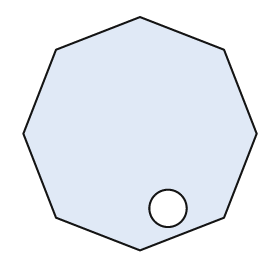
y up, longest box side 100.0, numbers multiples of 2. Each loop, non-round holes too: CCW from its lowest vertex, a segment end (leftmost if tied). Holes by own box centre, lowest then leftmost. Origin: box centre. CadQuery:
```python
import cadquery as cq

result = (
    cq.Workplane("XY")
    .moveTo(0.0, -50.0)
    .lineTo(36.0, -36.0)
    .lineTo(50.0, 0.0)
    .lineTo(36.0, 36.0)
    .lineTo(0.0, 50.0)
    .lineTo(-36.0, 36.0)
    .lineTo(-50.0, 0.0)
    .lineTo(-36.0, -36.0)
    .close()
    .moveTo(12.0, -32.0)
    .circle(8.0)
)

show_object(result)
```